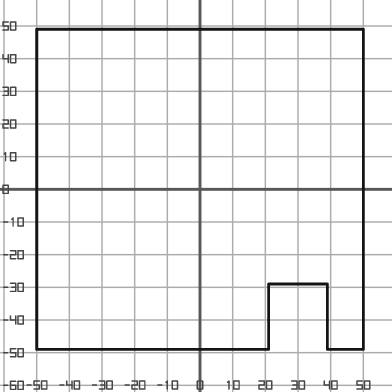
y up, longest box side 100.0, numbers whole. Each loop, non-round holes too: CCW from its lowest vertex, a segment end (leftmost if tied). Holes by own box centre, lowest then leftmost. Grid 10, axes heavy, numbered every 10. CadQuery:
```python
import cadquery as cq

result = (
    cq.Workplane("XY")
    .moveTo(-50.0, -49.0)
    .lineTo(21.0, -49.0)
    .lineTo(21.0, -29.0)
    .lineTo(39.0, -29.0)
    .lineTo(39.0, -49.0)
    .lineTo(50.0, -49.0)
    .lineTo(50.0, 49.0)
    .lineTo(-50.0, 49.0)
    .close()
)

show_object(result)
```